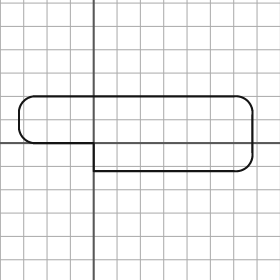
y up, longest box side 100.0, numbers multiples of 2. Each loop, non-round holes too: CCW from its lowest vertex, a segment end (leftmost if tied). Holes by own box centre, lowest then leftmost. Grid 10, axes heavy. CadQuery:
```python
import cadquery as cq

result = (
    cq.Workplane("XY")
    .moveTo(0.0, -12.0)
    .lineTo(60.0, -12.0)
    .threePointArc((66.0, -10.0), (68.0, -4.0))
    .lineTo(68.0, 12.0)
    .threePointArc((66.0, 18.0), (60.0, 20.0))
    .lineTo(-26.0, 20.0)
    .threePointArc((-30.0, 18.0), (-32.0, 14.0))
    .lineTo(-32.0, 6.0)
    .threePointArc((-30.0, 2.0), (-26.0, 0.0))
    .lineTo(0.0, 0.0)
    .close()
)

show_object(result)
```